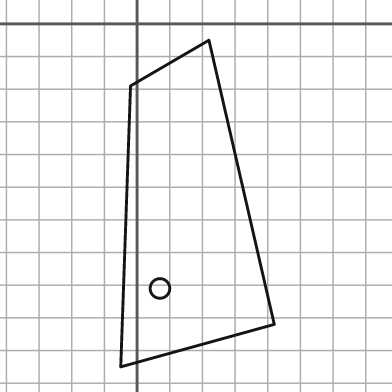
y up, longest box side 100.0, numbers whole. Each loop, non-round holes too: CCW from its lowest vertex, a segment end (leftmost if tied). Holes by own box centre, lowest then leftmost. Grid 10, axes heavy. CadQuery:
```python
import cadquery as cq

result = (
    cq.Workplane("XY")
    .moveTo(-5.0, -105.0)
    .lineTo(42.0, -92.0)
    .lineTo(22.0, -5.0)
    .lineTo(-2.0, -19.0)
    .close()
    .moveTo(7.0, -81.0)
    .circle(3.0)
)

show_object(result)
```